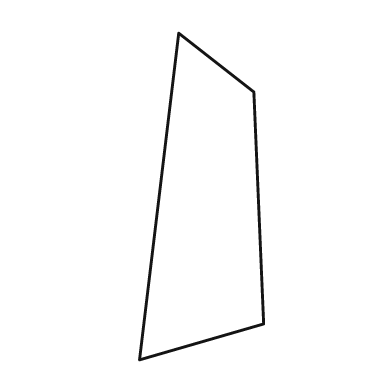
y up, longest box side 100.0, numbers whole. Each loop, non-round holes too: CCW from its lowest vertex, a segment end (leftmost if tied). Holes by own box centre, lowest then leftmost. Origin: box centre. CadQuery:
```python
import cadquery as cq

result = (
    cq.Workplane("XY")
    .moveTo(-19.0, -50.0)
    .lineTo(19.0, -39.0)
    .lineTo(16.0, 32.0)
    .lineTo(-7.0, 50.0)
    .close()
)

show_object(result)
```